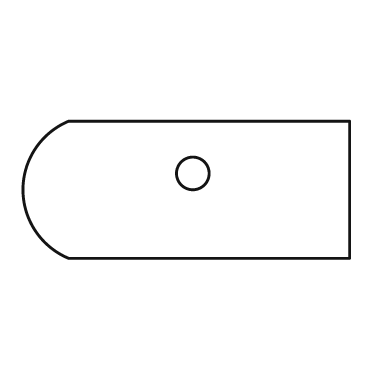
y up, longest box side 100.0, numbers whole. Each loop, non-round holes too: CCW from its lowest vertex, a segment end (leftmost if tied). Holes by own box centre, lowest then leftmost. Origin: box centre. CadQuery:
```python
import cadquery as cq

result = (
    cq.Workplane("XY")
    .moveTo(-36.0, -21.0)
    .lineTo(50.0, -21.0)
    .lineTo(50.0, 21.0)
    .lineTo(-36.0, 21.0)
    .threePointArc((-50.0, 0.0), (-36.0, -21.0))
    .close()
    .moveTo(2.0, 5.0)
    .circle(5.0)
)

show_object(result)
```